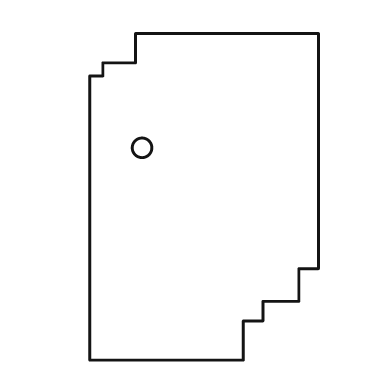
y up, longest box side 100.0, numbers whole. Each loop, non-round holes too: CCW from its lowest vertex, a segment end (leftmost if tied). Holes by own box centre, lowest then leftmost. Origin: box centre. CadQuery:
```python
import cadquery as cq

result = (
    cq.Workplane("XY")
    .moveTo(-35.0, -50.0)
    .lineTo(12.0, -50.0)
    .lineTo(12.0, -38.0)
    .lineTo(18.0, -38.0)
    .lineTo(18.0, -32.0)
    .lineTo(29.0, -32.0)
    .lineTo(29.0, -22.0)
    .lineTo(35.0, -22.0)
    .lineTo(35.0, 50.0)
    .lineTo(-21.0, 50.0)
    .lineTo(-21.0, 41.0)
    .lineTo(-31.0, 41.0)
    .lineTo(-31.0, 37.0)
    .lineTo(-35.0, 37.0)
    .close()
    .moveTo(-19.0, 15.0)
    .circle(3.0)
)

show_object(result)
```